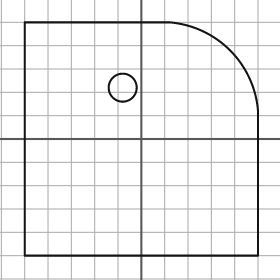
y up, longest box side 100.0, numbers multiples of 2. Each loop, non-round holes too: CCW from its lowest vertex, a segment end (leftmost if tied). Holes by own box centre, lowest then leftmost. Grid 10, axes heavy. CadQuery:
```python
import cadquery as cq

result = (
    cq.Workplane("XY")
    .moveTo(-50.0, -50.0)
    .lineTo(50.0, -50.0)
    .lineTo(50.0, 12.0)
    .threePointArc((38.0, 38.0), (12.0, 50.0))
    .lineTo(-50.0, 50.0)
    .close()
    .moveTo(-8.0, 22.0)
    .circle(6.0)
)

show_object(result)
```